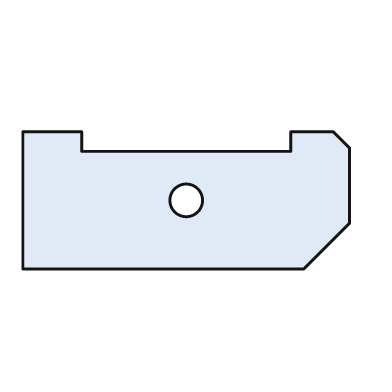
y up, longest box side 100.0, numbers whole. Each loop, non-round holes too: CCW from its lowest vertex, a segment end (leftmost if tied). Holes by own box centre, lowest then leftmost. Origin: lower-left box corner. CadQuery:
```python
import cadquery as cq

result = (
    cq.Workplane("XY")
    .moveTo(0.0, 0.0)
    .lineTo(86.0, 0.0)
    .lineTo(100.0, 14.0)
    .lineTo(100.0, 37.0)
    .lineTo(95.0, 42.0)
    .lineTo(82.0, 42.0)
    .lineTo(82.0, 36.0)
    .lineTo(18.0, 36.0)
    .lineTo(18.0, 42.0)
    .lineTo(0.0, 42.0)
    .close()
    .moveTo(50.0, 21.0)
    .circle(5.0)
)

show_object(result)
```